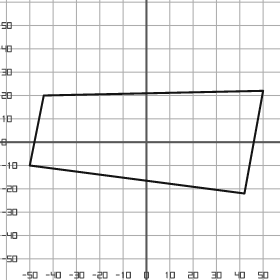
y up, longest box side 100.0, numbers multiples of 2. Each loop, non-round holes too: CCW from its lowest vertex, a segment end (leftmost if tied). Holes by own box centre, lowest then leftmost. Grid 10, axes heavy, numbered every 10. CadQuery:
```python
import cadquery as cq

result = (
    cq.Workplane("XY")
    .moveTo(42.0, -22.0)
    .lineTo(50.0, 22.0)
    .lineTo(-44.0, 20.0)
    .lineTo(-50.0, -10.0)
    .close()
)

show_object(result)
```